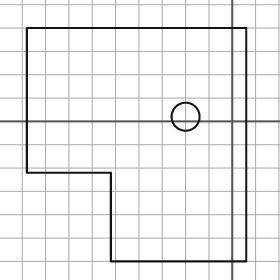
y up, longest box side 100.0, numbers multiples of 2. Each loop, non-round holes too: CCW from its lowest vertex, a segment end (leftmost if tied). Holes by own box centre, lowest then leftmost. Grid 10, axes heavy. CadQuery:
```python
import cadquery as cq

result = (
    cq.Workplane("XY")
    .moveTo(-52.0, -60.0)
    .lineTo(6.0, -60.0)
    .lineTo(6.0, 40.0)
    .lineTo(-88.0, 40.0)
    .lineTo(-88.0, -22.0)
    .lineTo(-52.0, -22.0)
    .close()
    .moveTo(-20.0, 2.0)
    .circle(6.0)
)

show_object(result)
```